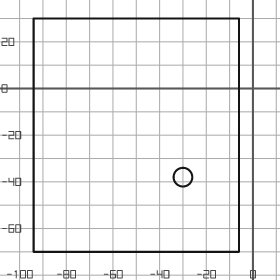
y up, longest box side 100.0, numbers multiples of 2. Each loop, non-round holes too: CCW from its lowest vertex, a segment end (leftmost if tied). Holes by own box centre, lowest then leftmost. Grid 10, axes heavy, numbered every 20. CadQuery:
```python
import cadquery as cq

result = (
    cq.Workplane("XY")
    .moveTo(-94.0, -70.0)
    .lineTo(-6.0, -70.0)
    .lineTo(-6.0, 30.0)
    .lineTo(-94.0, 30.0)
    .close()
    .moveTo(-30.0, -38.0)
    .circle(4.0)
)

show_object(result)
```